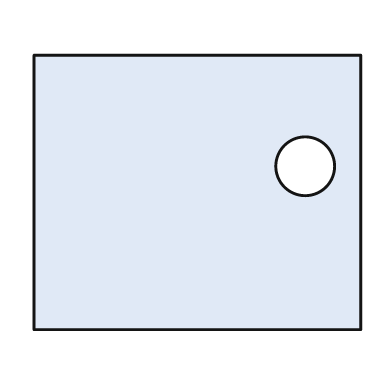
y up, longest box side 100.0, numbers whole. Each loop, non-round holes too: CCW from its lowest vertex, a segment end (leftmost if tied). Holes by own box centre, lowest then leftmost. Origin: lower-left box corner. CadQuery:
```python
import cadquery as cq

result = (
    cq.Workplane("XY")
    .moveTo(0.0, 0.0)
    .lineTo(100.0, 0.0)
    .lineTo(100.0, 84.0)
    .lineTo(0.0, 84.0)
    .close()
    .moveTo(83.0, 50.0)
    .circle(9.0)
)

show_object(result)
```